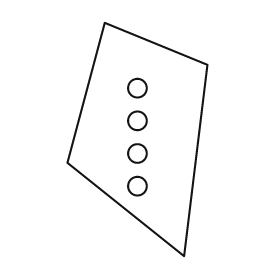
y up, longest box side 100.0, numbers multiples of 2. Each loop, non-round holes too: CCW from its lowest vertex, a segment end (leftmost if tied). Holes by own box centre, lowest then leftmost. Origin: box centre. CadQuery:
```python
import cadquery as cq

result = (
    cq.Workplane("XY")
    .moveTo(20.0, -50.0)
    .lineTo(30.0, 32.0)
    .lineTo(-14.0, 50.0)
    .lineTo(-30.0, -10.0)
    .close()
    .moveTo(0.0, -20.0)
    .circle(4.0)
    .moveTo(0.0, -6.0)
    .circle(4.0)
    .moveTo(0.0, 8.0)
    .circle(4.0)
    .moveTo(0.0, 22.0)
    .circle(4.0)
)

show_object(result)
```